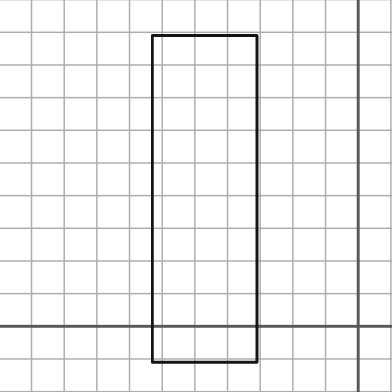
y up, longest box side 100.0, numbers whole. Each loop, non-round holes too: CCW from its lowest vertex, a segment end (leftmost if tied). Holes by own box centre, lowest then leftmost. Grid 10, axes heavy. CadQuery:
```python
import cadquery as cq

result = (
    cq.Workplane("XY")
    .moveTo(-63.0, -11.0)
    .lineTo(-31.0, -11.0)
    .lineTo(-31.0, 89.0)
    .lineTo(-63.0, 89.0)
    .close()
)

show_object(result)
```